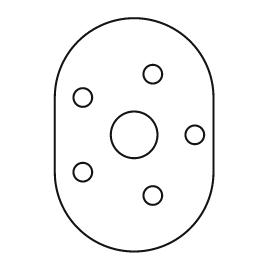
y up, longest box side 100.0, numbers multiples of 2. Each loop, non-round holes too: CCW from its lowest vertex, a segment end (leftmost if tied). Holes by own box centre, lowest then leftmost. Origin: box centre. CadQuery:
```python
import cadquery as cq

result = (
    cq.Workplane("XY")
    .moveTo(-34.0, -16.0)
    .threePointArc((0.0, -50.0), (34.0, -16.0))
    .lineTo(34.0, 16.0)
    .threePointArc((0.0, 50.0), (-34.0, 16.0))
    .close()
    .moveTo(8.0, -26.0)
    .circle(4.0)
    .moveTo(-22.0, -16.0)
    .circle(4.0)
    .moveTo(0.0, 0.0)
    .circle(10.0)
    .moveTo(26.0, 0.0)
    .circle(4.0)
    .moveTo(-22.0, 16.0)
    .circle(4.0)
    .moveTo(8.0, 26.0)
    .circle(4.0)
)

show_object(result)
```